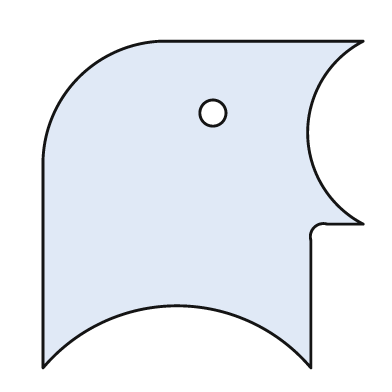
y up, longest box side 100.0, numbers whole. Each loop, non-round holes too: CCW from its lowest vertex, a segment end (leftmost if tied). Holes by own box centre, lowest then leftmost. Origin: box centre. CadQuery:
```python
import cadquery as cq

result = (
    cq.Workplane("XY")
    .moveTo(-49.0, -50.0)
    .threePointArc((-8.0, -31.0), (33.0, -50.0))
    .lineTo(33.0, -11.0)
    .threePointArc((34.0, -7.0), (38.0, -6.0))
    .lineTo(49.0, -6.0)
    .threePointArc((32.0, 22.0), (49.0, 50.0))
    .lineTo(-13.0, 50.0)
    .threePointArc((-38.0, 39.0), (-49.0, 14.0))
    .close()
    .moveTo(3.0, 28.0)
    .circle(4.0)
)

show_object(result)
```